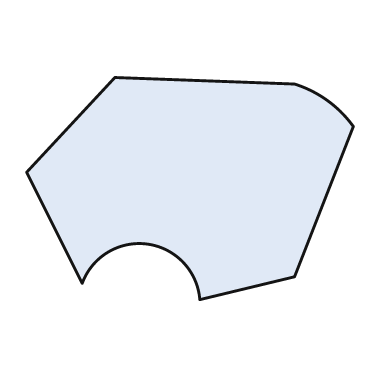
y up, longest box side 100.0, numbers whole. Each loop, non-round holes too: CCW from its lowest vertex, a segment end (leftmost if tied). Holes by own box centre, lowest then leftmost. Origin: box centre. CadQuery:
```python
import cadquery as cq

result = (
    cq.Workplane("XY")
    .moveTo(3.0, -34.0)
    .lineTo(32.0, -27.0)
    .lineTo(50.0, 19.0)
    .threePointArc((42.0, 27.0), (32.0, 32.0))
    .lineTo(-23.0, 34.0)
    .lineTo(-50.0, 5.0)
    .lineTo(-33.0, -29.0)
    .threePointArc((-13.0, -17.0), (3.0, -34.0))
    .close()
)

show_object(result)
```